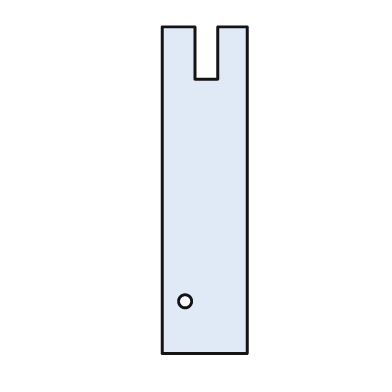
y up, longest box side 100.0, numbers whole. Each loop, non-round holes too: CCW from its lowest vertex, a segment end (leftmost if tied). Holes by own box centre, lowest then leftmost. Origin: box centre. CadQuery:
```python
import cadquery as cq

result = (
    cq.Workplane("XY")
    .moveTo(-13.0, -50.0)
    .lineTo(13.0, -50.0)
    .lineTo(13.0, 50.0)
    .lineTo(4.0, 50.0)
    .lineTo(4.0, 34.0)
    .lineTo(-3.0, 34.0)
    .lineTo(-3.0, 50.0)
    .lineTo(-13.0, 50.0)
    .close()
    .moveTo(-6.0, -34.0)
    .circle(2.0)
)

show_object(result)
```